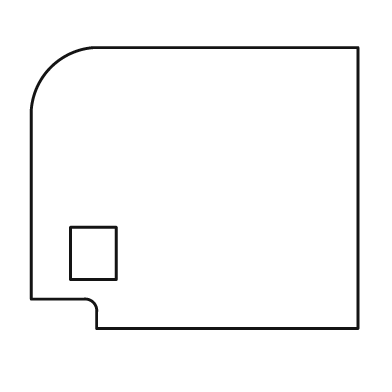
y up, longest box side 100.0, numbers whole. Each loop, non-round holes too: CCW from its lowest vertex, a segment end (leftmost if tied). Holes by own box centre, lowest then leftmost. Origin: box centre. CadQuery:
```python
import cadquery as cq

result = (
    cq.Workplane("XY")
    .moveTo(-30.0, -43.0)
    .lineTo(50.0, -43.0)
    .lineTo(50.0, 43.0)
    .lineTo(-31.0, 43.0)
    .threePointArc((-44.0, 37.0), (-50.0, 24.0))
    .lineTo(-50.0, -34.0)
    .lineTo(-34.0, -34.0)
    .threePointArc((-31.0, -35.0), (-30.0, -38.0))
    .close()
    .moveTo(-38.0, -28.0)
    .lineTo(-24.0, -28.0)
    .lineTo(-24.0, -12.0)
    .lineTo(-38.0, -12.0)
    .close()
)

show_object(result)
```